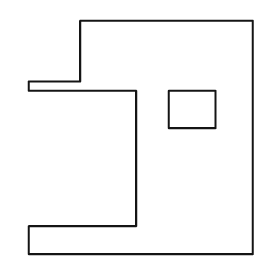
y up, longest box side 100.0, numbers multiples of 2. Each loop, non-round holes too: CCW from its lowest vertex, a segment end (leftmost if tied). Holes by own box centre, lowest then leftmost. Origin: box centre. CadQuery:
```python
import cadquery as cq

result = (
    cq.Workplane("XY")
    .moveTo(-48.0, -50.0)
    .lineTo(48.0, -50.0)
    .lineTo(48.0, 50.0)
    .lineTo(-26.0, 50.0)
    .lineTo(-26.0, 24.0)
    .lineTo(-48.0, 24.0)
    .lineTo(-48.0, 20.0)
    .lineTo(-2.0, 20.0)
    .lineTo(-2.0, -38.0)
    .lineTo(-48.0, -38.0)
    .close()
    .moveTo(12.0, 4.0)
    .lineTo(32.0, 4.0)
    .lineTo(32.0, 20.0)
    .lineTo(12.0, 20.0)
    .close()
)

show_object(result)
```